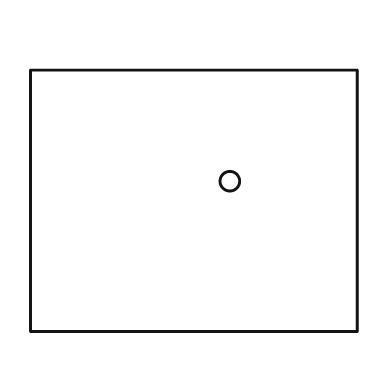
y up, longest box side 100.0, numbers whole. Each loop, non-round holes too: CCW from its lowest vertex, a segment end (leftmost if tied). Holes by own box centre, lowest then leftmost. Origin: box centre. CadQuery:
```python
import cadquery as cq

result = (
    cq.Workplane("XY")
    .moveTo(-50.0, -40.0)
    .lineTo(50.0, -40.0)
    .lineTo(50.0, 40.0)
    .lineTo(-50.0, 40.0)
    .close()
    .moveTo(11.0, 6.0)
    .circle(3.0)
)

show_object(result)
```